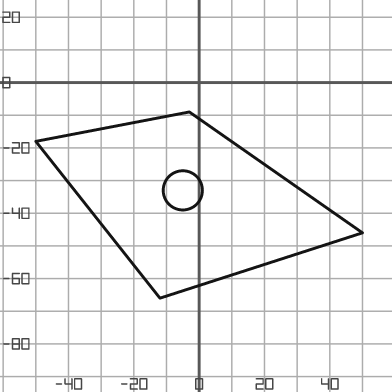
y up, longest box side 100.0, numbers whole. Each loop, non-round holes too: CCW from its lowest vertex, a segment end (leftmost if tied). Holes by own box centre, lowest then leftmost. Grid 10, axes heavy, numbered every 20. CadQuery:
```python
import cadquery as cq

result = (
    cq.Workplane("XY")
    .moveTo(-12.0, -66.0)
    .lineTo(50.0, -46.0)
    .lineTo(-3.0, -9.0)
    .lineTo(-50.0, -18.0)
    .close()
    .moveTo(-5.0, -33.0)
    .circle(6.0)
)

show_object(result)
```